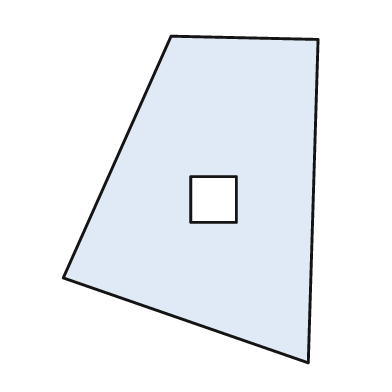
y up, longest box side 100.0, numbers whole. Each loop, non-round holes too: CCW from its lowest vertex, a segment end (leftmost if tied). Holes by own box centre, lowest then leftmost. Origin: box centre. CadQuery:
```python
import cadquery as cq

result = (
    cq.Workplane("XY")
    .moveTo(36.0, -50.0)
    .lineTo(39.0, 49.0)
    .lineTo(-6.0, 50.0)
    .lineTo(-39.0, -24.0)
    .close()
    .moveTo(0.0, -7.0)
    .lineTo(14.0, -7.0)
    .lineTo(14.0, 7.0)
    .lineTo(0.0, 7.0)
    .close()
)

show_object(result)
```